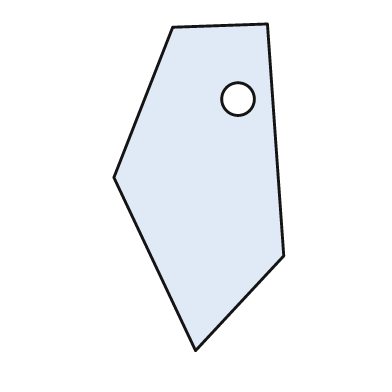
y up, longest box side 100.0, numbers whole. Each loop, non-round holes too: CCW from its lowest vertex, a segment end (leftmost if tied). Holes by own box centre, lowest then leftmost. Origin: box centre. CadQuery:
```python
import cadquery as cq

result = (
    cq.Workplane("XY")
    .moveTo(-1.0, -50.0)
    .lineTo(26.0, -21.0)
    .lineTo(21.0, 50.0)
    .lineTo(-8.0, 49.0)
    .lineTo(-26.0, 3.0)
    .close()
    .moveTo(12.0, 27.0)
    .circle(5.0)
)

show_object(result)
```